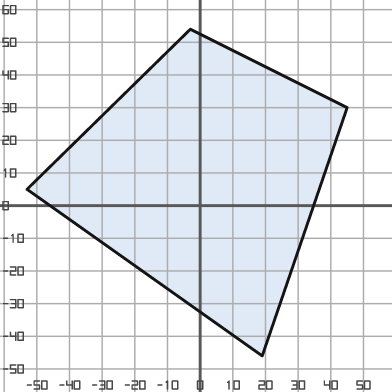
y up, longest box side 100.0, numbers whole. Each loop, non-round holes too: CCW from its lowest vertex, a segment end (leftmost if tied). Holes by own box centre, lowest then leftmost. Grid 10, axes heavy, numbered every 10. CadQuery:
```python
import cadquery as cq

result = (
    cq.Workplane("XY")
    .moveTo(19.0, -46.0)
    .lineTo(45.0, 30.0)
    .lineTo(-3.0, 54.0)
    .lineTo(-53.0, 5.0)
    .close()
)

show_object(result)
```